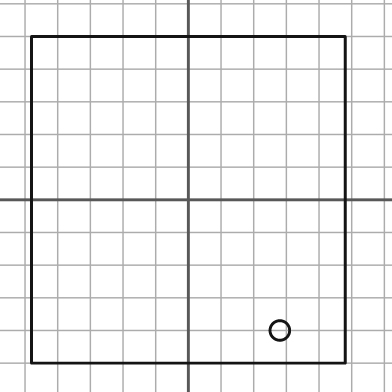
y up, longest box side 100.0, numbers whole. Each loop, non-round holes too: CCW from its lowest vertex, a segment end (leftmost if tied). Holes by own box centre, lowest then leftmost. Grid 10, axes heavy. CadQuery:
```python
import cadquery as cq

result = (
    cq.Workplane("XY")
    .moveTo(-48.0, -50.0)
    .lineTo(48.0, -50.0)
    .lineTo(48.0, 50.0)
    .lineTo(-48.0, 50.0)
    .close()
    .moveTo(28.0, -40.0)
    .circle(3.0)
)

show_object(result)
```